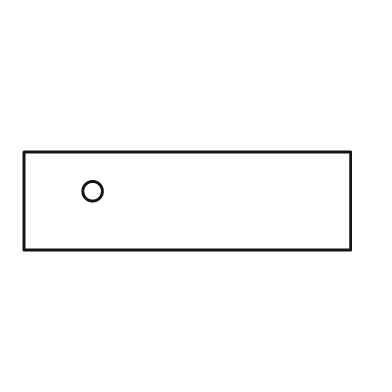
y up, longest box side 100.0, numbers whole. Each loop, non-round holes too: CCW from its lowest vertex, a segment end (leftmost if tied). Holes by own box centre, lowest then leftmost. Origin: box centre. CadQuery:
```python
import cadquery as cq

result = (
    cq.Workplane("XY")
    .moveTo(-50.0, -15.0)
    .lineTo(50.0, -15.0)
    .lineTo(50.0, 15.0)
    .lineTo(-50.0, 15.0)
    .close()
    .moveTo(-29.0, 3.0)
    .circle(3.0)
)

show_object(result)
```